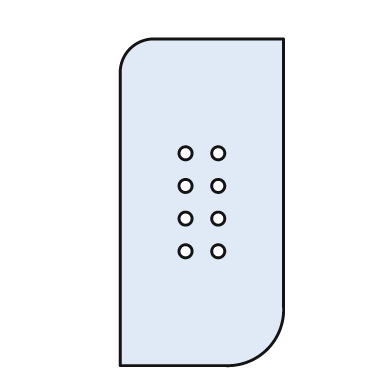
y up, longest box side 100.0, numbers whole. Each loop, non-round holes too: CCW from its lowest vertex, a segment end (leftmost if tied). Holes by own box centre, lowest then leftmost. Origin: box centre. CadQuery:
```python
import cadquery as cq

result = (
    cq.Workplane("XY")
    .moveTo(-25.0, -50.0)
    .lineTo(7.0, -50.0)
    .threePointArc((20.0, -45.0), (25.0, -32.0))
    .lineTo(25.0, 50.0)
    .lineTo(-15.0, 50.0)
    .threePointArc((-22.0, 47.0), (-25.0, 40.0))
    .close()
    .moveTo(-5.0, -15.0)
    .circle(2.0)
    .moveTo(5.0, -15.0)
    .circle(2.0)
    .moveTo(-5.0, -5.0)
    .circle(2.0)
    .moveTo(5.0, -5.0)
    .circle(2.0)
    .moveTo(-5.0, 5.0)
    .circle(2.0)
    .moveTo(5.0, 5.0)
    .circle(2.0)
    .moveTo(-5.0, 15.0)
    .circle(2.0)
    .moveTo(5.0, 15.0)
    .circle(2.0)
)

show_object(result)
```